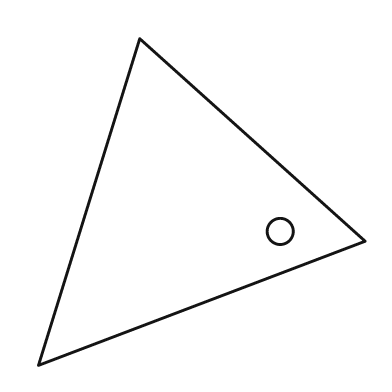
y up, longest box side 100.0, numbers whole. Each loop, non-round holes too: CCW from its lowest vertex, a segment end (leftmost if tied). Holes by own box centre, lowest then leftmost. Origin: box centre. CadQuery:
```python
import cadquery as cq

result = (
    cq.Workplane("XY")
    .moveTo(-50.0, -50.0)
    .lineTo(50.0, -12.0)
    .lineTo(-19.0, 50.0)
    .close()
    .moveTo(24.0, -9.0)
    .circle(4.0)
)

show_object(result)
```